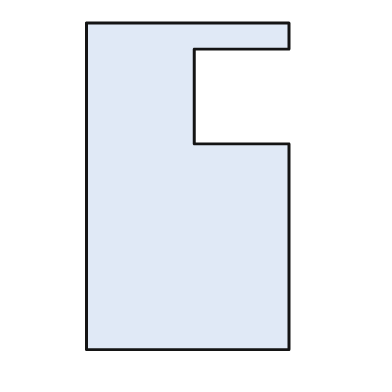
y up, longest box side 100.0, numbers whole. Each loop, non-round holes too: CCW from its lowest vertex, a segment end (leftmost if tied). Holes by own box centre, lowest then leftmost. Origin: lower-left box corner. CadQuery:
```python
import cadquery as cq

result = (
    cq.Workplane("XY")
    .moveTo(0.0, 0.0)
    .lineTo(62.0, 0.0)
    .lineTo(62.0, 63.0)
    .lineTo(33.0, 63.0)
    .lineTo(33.0, 92.0)
    .lineTo(62.0, 92.0)
    .lineTo(62.0, 100.0)
    .lineTo(0.0, 100.0)
    .close()
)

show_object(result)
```